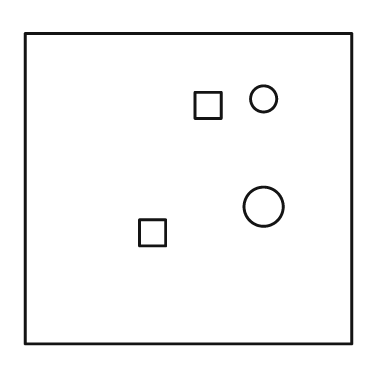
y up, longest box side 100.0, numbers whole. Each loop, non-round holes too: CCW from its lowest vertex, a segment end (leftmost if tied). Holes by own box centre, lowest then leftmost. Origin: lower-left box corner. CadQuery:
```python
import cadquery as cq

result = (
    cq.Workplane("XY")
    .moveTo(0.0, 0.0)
    .lineTo(100.0, 0.0)
    .lineTo(100.0, 95.0)
    .lineTo(0.0, 95.0)
    .close()
    .moveTo(35.0, 30.0)
    .lineTo(43.0, 30.0)
    .lineTo(43.0, 38.0)
    .lineTo(35.0, 38.0)
    .close()
    .moveTo(73.0, 42.0)
    .circle(6.0)
    .moveTo(52.0, 69.0)
    .lineTo(60.0, 69.0)
    .lineTo(60.0, 77.0)
    .lineTo(52.0, 77.0)
    .close()
    .moveTo(73.0, 75.0)
    .circle(4.0)
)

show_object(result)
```